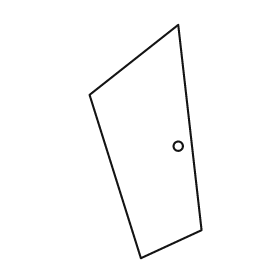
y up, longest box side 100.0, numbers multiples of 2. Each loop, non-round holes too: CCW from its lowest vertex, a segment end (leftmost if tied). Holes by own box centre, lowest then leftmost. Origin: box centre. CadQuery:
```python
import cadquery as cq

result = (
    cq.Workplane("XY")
    .moveTo(-2.0, -50.0)
    .lineTo(24.0, -38.0)
    .lineTo(14.0, 50.0)
    .lineTo(-24.0, 20.0)
    .close()
    .moveTo(14.0, -2.0)
    .circle(2.0)
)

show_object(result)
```